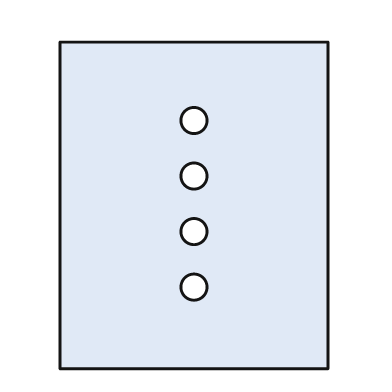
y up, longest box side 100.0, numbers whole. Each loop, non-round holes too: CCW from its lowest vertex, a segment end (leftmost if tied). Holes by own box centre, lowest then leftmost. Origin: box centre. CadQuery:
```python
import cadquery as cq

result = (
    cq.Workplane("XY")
    .moveTo(-41.0, -50.0)
    .lineTo(41.0, -50.0)
    .lineTo(41.0, 50.0)
    .lineTo(-41.0, 50.0)
    .close()
    .moveTo(0.0, -25.0)
    .circle(4.0)
    .moveTo(0.0, -8.0)
    .circle(4.0)
    .moveTo(0.0, 9.0)
    .circle(4.0)
    .moveTo(0.0, 26.0)
    .circle(4.0)
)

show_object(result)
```